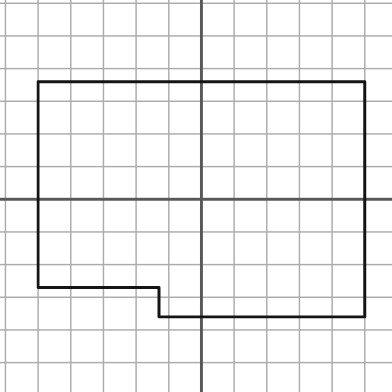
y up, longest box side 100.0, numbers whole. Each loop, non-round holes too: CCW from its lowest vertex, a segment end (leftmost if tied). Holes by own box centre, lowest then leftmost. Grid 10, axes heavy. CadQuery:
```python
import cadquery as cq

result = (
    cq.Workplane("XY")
    .moveTo(-13.0, -36.0)
    .lineTo(50.0, -36.0)
    .lineTo(50.0, 36.0)
    .lineTo(-50.0, 36.0)
    .lineTo(-50.0, -27.0)
    .lineTo(-13.0, -27.0)
    .close()
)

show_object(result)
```